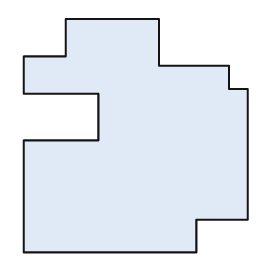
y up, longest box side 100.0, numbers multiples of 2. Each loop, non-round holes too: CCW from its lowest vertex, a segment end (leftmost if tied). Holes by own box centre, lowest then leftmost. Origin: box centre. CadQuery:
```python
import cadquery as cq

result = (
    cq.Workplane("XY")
    .moveTo(-48.0, -50.0)
    .lineTo(26.0, -50.0)
    .lineTo(26.0, -36.0)
    .lineTo(48.0, -36.0)
    .lineTo(48.0, 20.0)
    .lineTo(40.0, 20.0)
    .lineTo(40.0, 30.0)
    .lineTo(10.0, 30.0)
    .lineTo(10.0, 50.0)
    .lineTo(-30.0, 50.0)
    .lineTo(-30.0, 34.0)
    .lineTo(-48.0, 34.0)
    .lineTo(-48.0, 18.0)
    .lineTo(-16.0, 18.0)
    .lineTo(-16.0, -2.0)
    .lineTo(-48.0, -2.0)
    .close()
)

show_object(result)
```